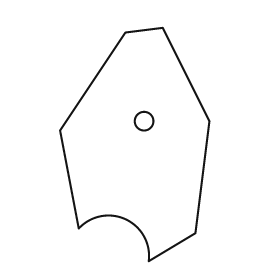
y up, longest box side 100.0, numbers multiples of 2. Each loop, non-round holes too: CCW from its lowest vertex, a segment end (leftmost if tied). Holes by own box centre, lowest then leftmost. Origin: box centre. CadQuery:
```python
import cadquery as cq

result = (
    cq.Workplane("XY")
    .moveTo(6.0, -50.0)
    .lineTo(26.0, -38.0)
    .lineTo(32.0, 10.0)
    .lineTo(12.0, 50.0)
    .lineTo(-4.0, 48.0)
    .lineTo(-32.0, 6.0)
    .lineTo(-24.0, -36.0)
    .threePointArc((-4.0, -32.0), (6.0, -50.0))
    .close()
    .moveTo(4.0, 10.0)
    .circle(4.0)
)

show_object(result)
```